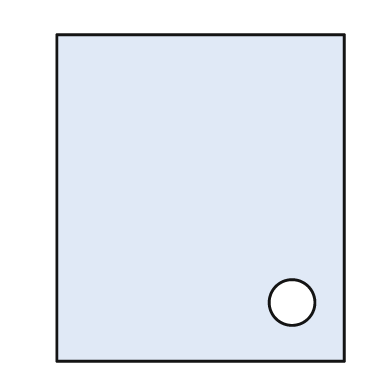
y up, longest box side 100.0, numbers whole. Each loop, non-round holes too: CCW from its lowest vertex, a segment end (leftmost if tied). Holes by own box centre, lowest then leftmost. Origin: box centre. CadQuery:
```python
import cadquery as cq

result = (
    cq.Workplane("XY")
    .moveTo(-44.0, -50.0)
    .lineTo(44.0, -50.0)
    .lineTo(44.0, 50.0)
    .lineTo(-44.0, 50.0)
    .close()
    .moveTo(28.0, -32.0)
    .circle(7.0)
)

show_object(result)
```